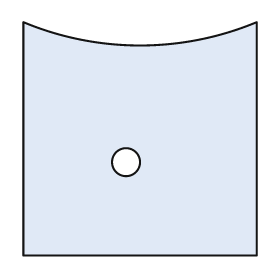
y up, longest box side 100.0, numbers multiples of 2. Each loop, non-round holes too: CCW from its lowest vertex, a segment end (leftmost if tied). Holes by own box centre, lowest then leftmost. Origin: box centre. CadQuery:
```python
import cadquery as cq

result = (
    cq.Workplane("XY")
    .moveTo(-50.0, -50.0)
    .lineTo(50.0, -50.0)
    .lineTo(50.0, 50.0)
    .threePointArc((0.0, 40.0), (-50.0, 50.0))
    .close()
    .moveTo(-6.0, -10.0)
    .circle(6.0)
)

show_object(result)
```